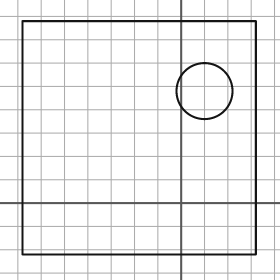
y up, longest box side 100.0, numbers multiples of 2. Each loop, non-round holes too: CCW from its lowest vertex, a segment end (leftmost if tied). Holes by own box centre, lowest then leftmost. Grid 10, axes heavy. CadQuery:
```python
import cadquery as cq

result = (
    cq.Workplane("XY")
    .moveTo(-68.0, -22.0)
    .lineTo(32.0, -22.0)
    .lineTo(32.0, 78.0)
    .lineTo(-68.0, 78.0)
    .close()
    .moveTo(10.0, 48.0)
    .circle(12.0)
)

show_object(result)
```